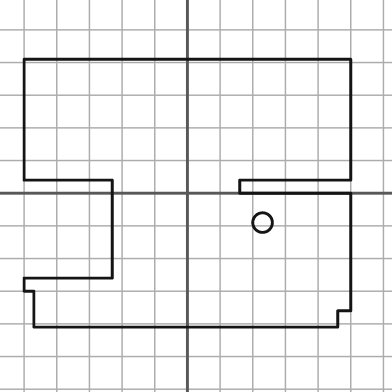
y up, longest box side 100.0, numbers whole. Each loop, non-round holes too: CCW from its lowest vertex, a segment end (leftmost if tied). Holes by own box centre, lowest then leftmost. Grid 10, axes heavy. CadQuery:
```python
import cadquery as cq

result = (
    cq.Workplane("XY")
    .moveTo(-47.0, -41.0)
    .lineTo(46.0, -41.0)
    .lineTo(46.0, -36.0)
    .lineTo(50.0, -36.0)
    .lineTo(50.0, 0.0)
    .lineTo(16.0, 0.0)
    .lineTo(16.0, 4.0)
    .lineTo(50.0, 4.0)
    .lineTo(50.0, 41.0)
    .lineTo(-50.0, 41.0)
    .lineTo(-50.0, 4.0)
    .lineTo(-23.0, 4.0)
    .lineTo(-23.0, -26.0)
    .lineTo(-50.0, -26.0)
    .lineTo(-50.0, -30.0)
    .lineTo(-47.0, -30.0)
    .close()
    .moveTo(23.0, -9.0)
    .circle(3.0)
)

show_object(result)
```